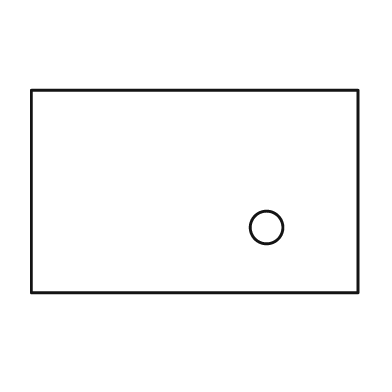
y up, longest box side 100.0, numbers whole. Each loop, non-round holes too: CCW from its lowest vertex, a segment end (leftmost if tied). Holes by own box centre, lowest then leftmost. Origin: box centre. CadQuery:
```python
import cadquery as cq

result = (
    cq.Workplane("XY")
    .moveTo(-50.0, -31.0)
    .lineTo(50.0, -31.0)
    .lineTo(50.0, 31.0)
    .lineTo(-50.0, 31.0)
    .close()
    .moveTo(22.0, -11.0)
    .circle(5.0)
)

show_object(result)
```